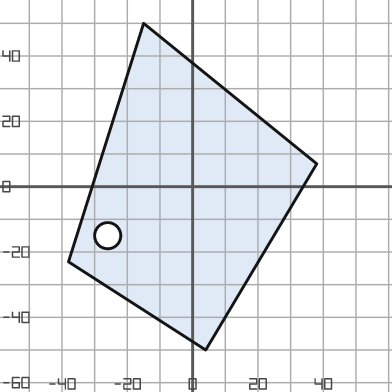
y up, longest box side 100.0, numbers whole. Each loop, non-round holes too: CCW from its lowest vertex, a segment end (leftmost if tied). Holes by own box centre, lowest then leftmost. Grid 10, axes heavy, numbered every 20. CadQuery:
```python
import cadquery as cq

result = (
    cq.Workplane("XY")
    .moveTo(4.0, -50.0)
    .lineTo(38.0, 7.0)
    .lineTo(-15.0, 50.0)
    .lineTo(-38.0, -23.0)
    .close()
    .moveTo(-26.0, -15.0)
    .circle(4.0)
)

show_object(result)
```